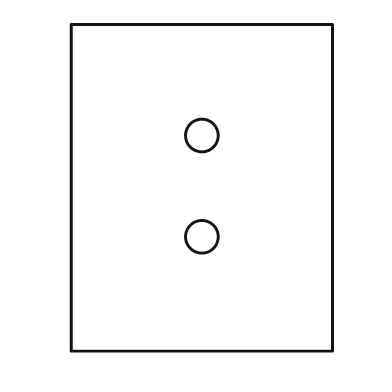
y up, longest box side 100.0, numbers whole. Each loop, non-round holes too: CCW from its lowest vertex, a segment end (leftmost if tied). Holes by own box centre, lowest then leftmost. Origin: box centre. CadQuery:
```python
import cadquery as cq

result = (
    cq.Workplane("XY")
    .moveTo(-40.0, -50.0)
    .lineTo(40.0, -50.0)
    .lineTo(40.0, 50.0)
    .lineTo(-40.0, 50.0)
    .close()
    .moveTo(0.0, -15.0)
    .circle(5.0)
    .moveTo(0.0, 16.0)
    .circle(5.0)
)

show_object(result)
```